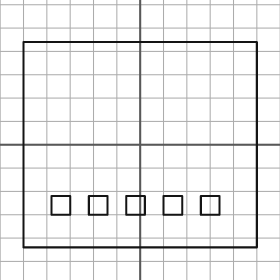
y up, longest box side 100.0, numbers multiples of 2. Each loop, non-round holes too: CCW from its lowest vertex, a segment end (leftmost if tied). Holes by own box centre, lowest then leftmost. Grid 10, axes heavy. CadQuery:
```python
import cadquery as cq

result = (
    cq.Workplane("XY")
    .moveTo(-50.0, -44.0)
    .lineTo(50.0, -44.0)
    .lineTo(50.0, 44.0)
    .lineTo(-50.0, 44.0)
    .close()
    .moveTo(-38.0, -30.0)
    .lineTo(-30.0, -30.0)
    .lineTo(-30.0, -22.0)
    .lineTo(-38.0, -22.0)
    .close()
    .moveTo(-22.0, -30.0)
    .lineTo(-14.0, -30.0)
    .lineTo(-14.0, -22.0)
    .lineTo(-22.0, -22.0)
    .close()
    .moveTo(-6.0, -30.0)
    .lineTo(2.0, -30.0)
    .lineTo(2.0, -22.0)
    .lineTo(-6.0, -22.0)
    .close()
    .moveTo(10.0, -30.0)
    .lineTo(18.0, -30.0)
    .lineTo(18.0, -22.0)
    .lineTo(10.0, -22.0)
    .close()
    .moveTo(26.0, -30.0)
    .lineTo(34.0, -30.0)
    .lineTo(34.0, -22.0)
    .lineTo(26.0, -22.0)
    .close()
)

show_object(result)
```